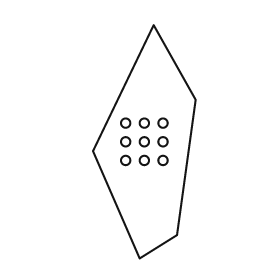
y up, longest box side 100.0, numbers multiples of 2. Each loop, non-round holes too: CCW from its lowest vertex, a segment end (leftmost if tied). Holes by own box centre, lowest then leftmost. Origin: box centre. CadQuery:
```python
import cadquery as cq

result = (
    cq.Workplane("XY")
    .moveTo(-2.0, -50.0)
    .lineTo(14.0, -40.0)
    .lineTo(22.0, 18.0)
    .lineTo(4.0, 50.0)
    .lineTo(-22.0, -4.0)
    .close()
    .moveTo(-8.0, -8.0)
    .circle(2.0)
    .moveTo(0.0, -8.0)
    .circle(2.0)
    .moveTo(8.0, -8.0)
    .circle(2.0)
    .moveTo(-8.0, 0.0)
    .circle(2.0)
    .moveTo(0.0, 0.0)
    .circle(2.0)
    .moveTo(8.0, 0.0)
    .circle(2.0)
    .moveTo(-8.0, 8.0)
    .circle(2.0)
    .moveTo(0.0, 8.0)
    .circle(2.0)
    .moveTo(8.0, 8.0)
    .circle(2.0)
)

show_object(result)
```